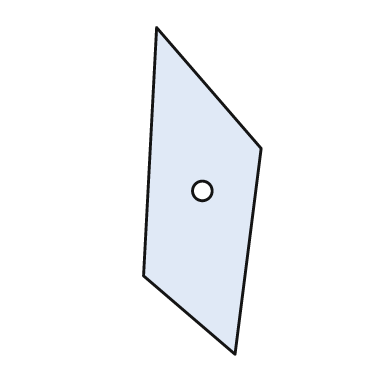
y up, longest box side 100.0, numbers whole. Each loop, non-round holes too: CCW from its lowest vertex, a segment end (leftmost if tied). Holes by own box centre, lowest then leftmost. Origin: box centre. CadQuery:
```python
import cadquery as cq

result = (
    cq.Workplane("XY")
    .moveTo(10.0, -50.0)
    .lineTo(18.0, 13.0)
    .lineTo(-14.0, 50.0)
    .lineTo(-18.0, -26.0)
    .close()
    .moveTo(0.0, 0.0)
    .circle(3.0)
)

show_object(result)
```